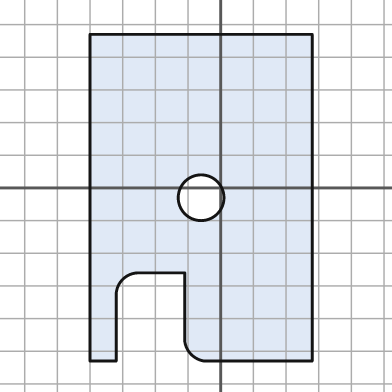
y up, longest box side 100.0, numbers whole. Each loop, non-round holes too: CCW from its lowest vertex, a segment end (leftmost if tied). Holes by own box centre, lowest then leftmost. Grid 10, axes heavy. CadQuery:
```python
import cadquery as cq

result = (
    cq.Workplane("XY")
    .moveTo(-40.0, -53.0)
    .lineTo(-32.0, -53.0)
    .lineTo(-32.0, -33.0)
    .threePointArc((-30.0, -28.0), (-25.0, -26.0))
    .lineTo(-11.0, -26.0)
    .lineTo(-11.0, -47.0)
    .threePointArc((-9.0, -51.0), (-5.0, -53.0))
    .lineTo(28.0, -53.0)
    .lineTo(28.0, 47.0)
    .lineTo(-40.0, 47.0)
    .close()
    .moveTo(-6.0, -3.0)
    .circle(7.0)
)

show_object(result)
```